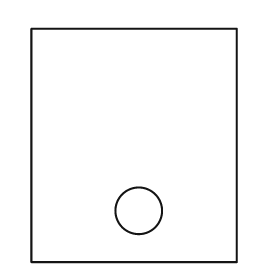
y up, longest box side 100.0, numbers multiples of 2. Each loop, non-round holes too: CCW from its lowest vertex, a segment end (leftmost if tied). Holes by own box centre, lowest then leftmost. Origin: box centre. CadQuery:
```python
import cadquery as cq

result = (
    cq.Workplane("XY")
    .moveTo(-44.0, -50.0)
    .lineTo(44.0, -50.0)
    .lineTo(44.0, 50.0)
    .lineTo(-44.0, 50.0)
    .close()
    .moveTo(2.0, -28.0)
    .circle(10.0)
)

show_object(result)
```